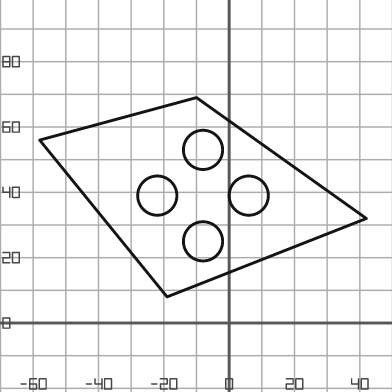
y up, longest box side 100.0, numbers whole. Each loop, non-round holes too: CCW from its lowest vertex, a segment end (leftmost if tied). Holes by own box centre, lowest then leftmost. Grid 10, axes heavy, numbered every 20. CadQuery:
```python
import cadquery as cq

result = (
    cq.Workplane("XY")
    .moveTo(-19.0, 8.0)
    .lineTo(42.0, 32.0)
    .lineTo(-10.0, 69.0)
    .lineTo(-58.0, 56.0)
    .close()
    .moveTo(-8.0, 25.0)
    .circle(6.0)
    .moveTo(-22.0, 39.0)
    .circle(6.0)
    .moveTo(6.0, 39.0)
    .circle(6.0)
    .moveTo(-8.0, 53.0)
    .circle(6.0)
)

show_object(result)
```